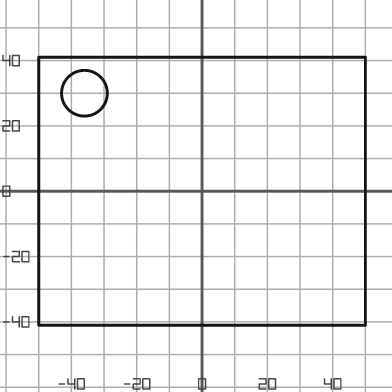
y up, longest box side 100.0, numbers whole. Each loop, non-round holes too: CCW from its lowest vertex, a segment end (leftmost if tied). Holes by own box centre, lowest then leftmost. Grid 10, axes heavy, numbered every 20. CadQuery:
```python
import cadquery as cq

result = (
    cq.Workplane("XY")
    .moveTo(-50.0, -41.0)
    .lineTo(50.0, -41.0)
    .lineTo(50.0, 41.0)
    .lineTo(-50.0, 41.0)
    .close()
    .moveTo(-36.0, 30.0)
    .circle(7.0)
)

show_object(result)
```